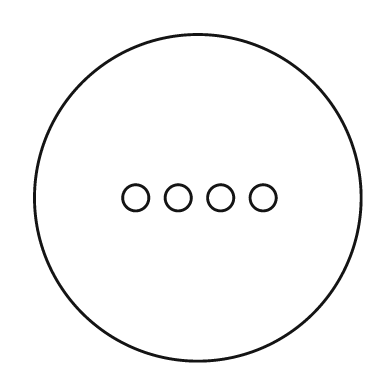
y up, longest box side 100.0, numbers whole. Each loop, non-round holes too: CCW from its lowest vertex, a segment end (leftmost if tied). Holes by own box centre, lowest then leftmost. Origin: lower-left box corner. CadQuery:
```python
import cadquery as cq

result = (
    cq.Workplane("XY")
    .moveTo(50.0, 50.0)
    .circle(50.0)
    .moveTo(31.0, 50.0)
    .circle(4.0)
    .moveTo(44.0, 50.0)
    .circle(4.0)
    .moveTo(57.0, 50.0)
    .circle(4.0)
    .moveTo(70.0, 50.0)
    .circle(4.0)
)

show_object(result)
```